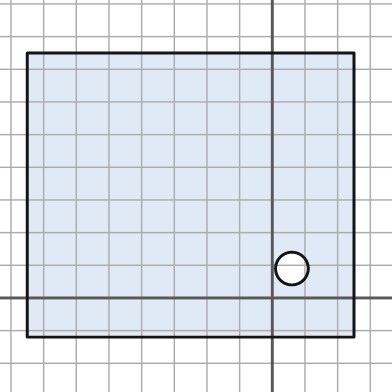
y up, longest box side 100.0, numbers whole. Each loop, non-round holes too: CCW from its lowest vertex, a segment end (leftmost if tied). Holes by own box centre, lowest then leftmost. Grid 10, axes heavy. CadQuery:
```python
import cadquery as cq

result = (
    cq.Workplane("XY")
    .moveTo(-75.0, -12.0)
    .lineTo(25.0, -12.0)
    .lineTo(25.0, 75.0)
    .lineTo(-75.0, 75.0)
    .close()
    .moveTo(6.0, 9.0)
    .circle(5.0)
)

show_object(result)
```